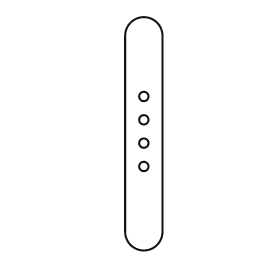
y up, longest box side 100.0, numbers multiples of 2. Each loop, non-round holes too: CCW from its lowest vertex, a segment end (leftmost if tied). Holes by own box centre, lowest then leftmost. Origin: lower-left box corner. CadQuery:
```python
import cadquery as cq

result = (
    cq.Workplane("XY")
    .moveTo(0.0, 8.0)
    .threePointArc((8.0, 0.0), (16.0, 8.0))
    .lineTo(16.0, 92.0)
    .threePointArc((8.0, 100.0), (0.0, 92.0))
    .close()
    .moveTo(8.0, 36.0)
    .circle(2.0)
    .moveTo(8.0, 46.0)
    .circle(2.0)
    .moveTo(8.0, 56.0)
    .circle(2.0)
    .moveTo(8.0, 66.0)
    .circle(2.0)
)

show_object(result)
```